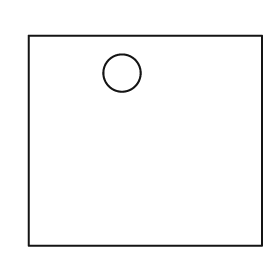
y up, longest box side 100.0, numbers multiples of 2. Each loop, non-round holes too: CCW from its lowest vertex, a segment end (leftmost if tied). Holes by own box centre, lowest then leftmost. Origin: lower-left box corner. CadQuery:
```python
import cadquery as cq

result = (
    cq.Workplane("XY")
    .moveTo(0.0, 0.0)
    .lineTo(100.0, 0.0)
    .lineTo(100.0, 90.0)
    .lineTo(0.0, 90.0)
    .close()
    .moveTo(40.0, 74.0)
    .circle(8.0)
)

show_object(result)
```